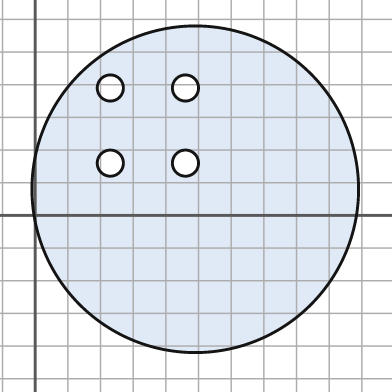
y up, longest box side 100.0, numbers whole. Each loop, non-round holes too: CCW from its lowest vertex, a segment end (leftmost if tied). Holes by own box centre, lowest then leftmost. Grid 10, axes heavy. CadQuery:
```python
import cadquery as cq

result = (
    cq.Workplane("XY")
    .moveTo(49.0, 8.0)
    .circle(50.0)
    .moveTo(23.0, 16.0)
    .circle(4.0)
    .moveTo(46.0, 16.0)
    .circle(4.0)
    .moveTo(23.0, 39.0)
    .circle(4.0)
    .moveTo(46.0, 39.0)
    .circle(4.0)
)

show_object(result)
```